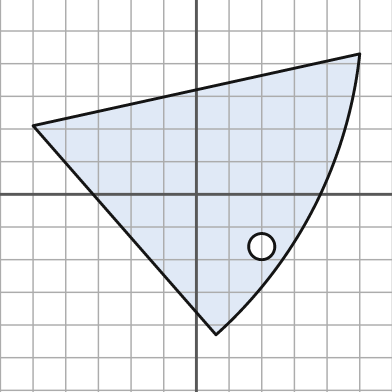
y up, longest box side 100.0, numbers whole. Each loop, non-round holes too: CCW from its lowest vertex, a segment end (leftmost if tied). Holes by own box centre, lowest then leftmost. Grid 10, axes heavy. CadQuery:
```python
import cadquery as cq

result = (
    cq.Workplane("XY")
    .moveTo(6.0, -43.0)
    .threePointArc((36.0, -4.0), (50.0, 43.0))
    .lineTo(-50.0, 21.0)
    .close()
    .moveTo(20.0, -16.0)
    .circle(4.0)
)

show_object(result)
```